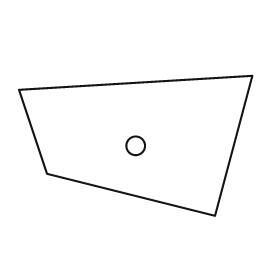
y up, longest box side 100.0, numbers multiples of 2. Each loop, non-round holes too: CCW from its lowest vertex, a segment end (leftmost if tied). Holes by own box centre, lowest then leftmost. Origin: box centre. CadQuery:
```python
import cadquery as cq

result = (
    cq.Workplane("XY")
    .moveTo(34.0, -30.0)
    .lineTo(50.0, 30.0)
    .lineTo(-50.0, 24.0)
    .lineTo(-38.0, -12.0)
    .close()
    .moveTo(0.0, 0.0)
    .circle(4.0)
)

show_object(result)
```